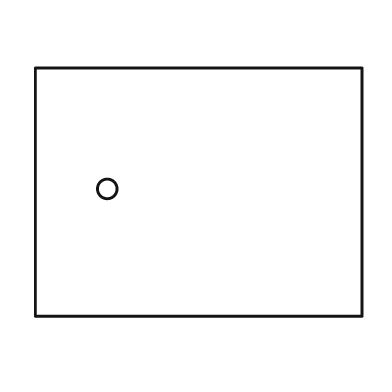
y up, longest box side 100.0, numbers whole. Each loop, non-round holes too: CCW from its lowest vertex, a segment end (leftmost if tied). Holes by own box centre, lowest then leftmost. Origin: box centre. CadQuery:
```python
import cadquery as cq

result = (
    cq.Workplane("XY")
    .moveTo(-50.0, -38.0)
    .lineTo(50.0, -38.0)
    .lineTo(50.0, 38.0)
    .lineTo(-50.0, 38.0)
    .close()
    .moveTo(-28.0, 1.0)
    .circle(3.0)
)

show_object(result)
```